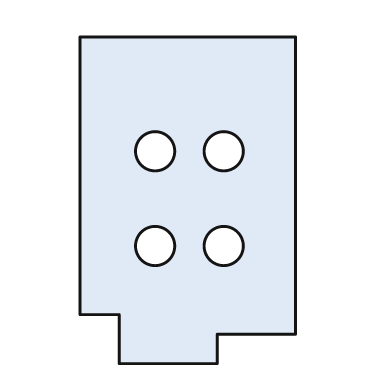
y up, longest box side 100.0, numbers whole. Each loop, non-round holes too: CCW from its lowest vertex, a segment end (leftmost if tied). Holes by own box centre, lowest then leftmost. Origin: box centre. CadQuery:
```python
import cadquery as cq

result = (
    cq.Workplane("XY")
    .moveTo(-21.0, -50.0)
    .lineTo(9.0, -50.0)
    .lineTo(9.0, -41.0)
    .lineTo(33.0, -41.0)
    .lineTo(33.0, 50.0)
    .lineTo(-33.0, 50.0)
    .lineTo(-33.0, -35.0)
    .lineTo(-21.0, -35.0)
    .close()
    .moveTo(-10.0, -14.0)
    .circle(6.0)
    .moveTo(11.0, -14.0)
    .circle(6.0)
    .moveTo(-10.0, 15.0)
    .circle(6.0)
    .moveTo(11.0, 15.0)
    .circle(6.0)
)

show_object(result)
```